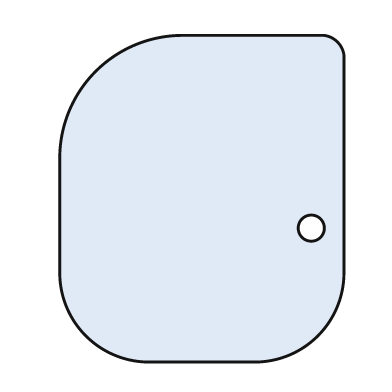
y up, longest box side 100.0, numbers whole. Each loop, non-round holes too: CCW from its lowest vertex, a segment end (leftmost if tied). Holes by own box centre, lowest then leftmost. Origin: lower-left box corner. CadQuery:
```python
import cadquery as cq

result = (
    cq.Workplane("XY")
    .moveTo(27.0, 0.0)
    .lineTo(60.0, 0.0)
    .threePointArc((79.0, 8.0), (87.0, 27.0))
    .lineTo(87.0, 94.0)
    .threePointArc((85.0, 98.0), (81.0, 100.0))
    .lineTo(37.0, 100.0)
    .threePointArc((11.0, 89.0), (0.0, 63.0))
    .lineTo(0.0, 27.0)
    .threePointArc((8.0, 8.0), (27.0, 0.0))
    .close()
    .moveTo(77.0, 41.0)
    .circle(4.0)
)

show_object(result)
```